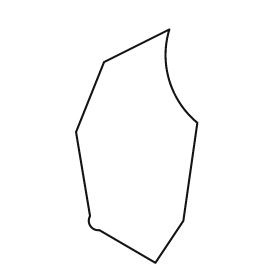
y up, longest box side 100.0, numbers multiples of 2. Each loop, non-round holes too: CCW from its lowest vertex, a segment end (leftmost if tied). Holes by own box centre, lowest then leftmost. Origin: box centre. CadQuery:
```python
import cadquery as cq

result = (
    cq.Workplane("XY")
    .moveTo(8.0, -50.0)
    .lineTo(20.0, -32.0)
    .lineTo(26.0, 10.0)
    .threePointArc((14.0, 28.0), (14.0, 50.0))
    .lineTo(-14.0, 36.0)
    .lineTo(-26.0, 6.0)
    .lineTo(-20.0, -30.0)
    .threePointArc((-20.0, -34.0), (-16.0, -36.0))
    .close()
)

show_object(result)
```